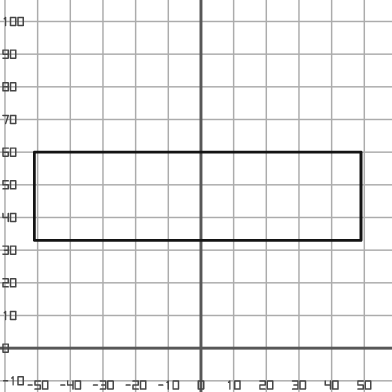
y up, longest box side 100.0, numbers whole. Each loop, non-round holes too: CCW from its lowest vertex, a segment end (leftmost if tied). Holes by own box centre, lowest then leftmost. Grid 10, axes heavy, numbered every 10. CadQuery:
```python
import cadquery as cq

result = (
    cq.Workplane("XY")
    .moveTo(-51.0, 33.0)
    .lineTo(49.0, 33.0)
    .lineTo(49.0, 60.0)
    .lineTo(-51.0, 60.0)
    .close()
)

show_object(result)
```